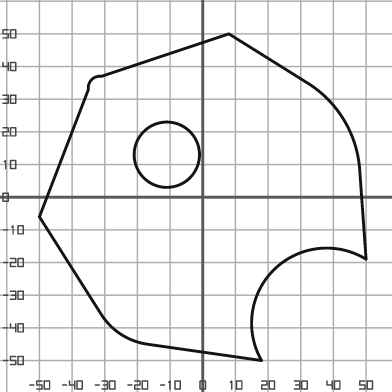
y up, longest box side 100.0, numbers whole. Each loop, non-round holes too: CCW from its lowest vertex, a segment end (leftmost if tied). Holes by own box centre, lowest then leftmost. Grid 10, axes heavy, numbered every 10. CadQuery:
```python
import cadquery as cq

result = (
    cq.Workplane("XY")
    .moveTo(18.0, -50.0)
    .threePointArc((22.0, -22.0), (50.0, -19.0))
    .lineTo(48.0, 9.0)
    .threePointArc((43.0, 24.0), (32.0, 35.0))
    .lineTo(8.0, 50.0)
    .lineTo(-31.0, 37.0)
    .threePointArc((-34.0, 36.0), (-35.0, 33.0))
    .lineTo(-50.0, -6.0)
    .lineTo(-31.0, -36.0)
    .threePointArc((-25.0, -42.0), (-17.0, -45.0))
    .close()
    .moveTo(-11.0, 13.0)
    .circle(10.0)
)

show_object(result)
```